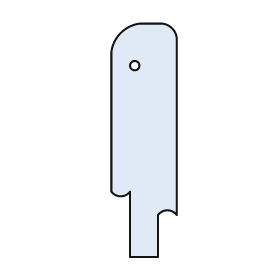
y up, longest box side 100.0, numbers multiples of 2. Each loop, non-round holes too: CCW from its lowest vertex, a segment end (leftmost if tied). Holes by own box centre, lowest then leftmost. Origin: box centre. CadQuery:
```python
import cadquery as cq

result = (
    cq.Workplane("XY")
    .moveTo(-6.0, -50.0)
    .lineTo(6.0, -50.0)
    .lineTo(6.0, -32.0)
    .threePointArc((10.0, -30.0), (14.0, -32.0))
    .lineTo(14.0, 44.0)
    .threePointArc((12.0, 48.0), (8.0, 50.0))
    .lineTo(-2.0, 50.0)
    .threePointArc((-10.0, 46.0), (-14.0, 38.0))
    .lineTo(-14.0, -22.0)
    .threePointArc((-10.0, -24.0), (-6.0, -22.0))
    .close()
    .moveTo(-4.0, 32.0)
    .circle(2.0)
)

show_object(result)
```